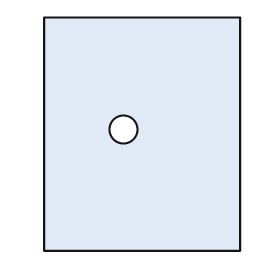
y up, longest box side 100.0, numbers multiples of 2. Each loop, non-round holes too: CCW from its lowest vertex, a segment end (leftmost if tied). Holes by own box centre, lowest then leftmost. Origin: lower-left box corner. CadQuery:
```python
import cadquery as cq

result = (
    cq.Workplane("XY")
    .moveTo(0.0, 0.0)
    .lineTo(84.0, 0.0)
    .lineTo(84.0, 100.0)
    .lineTo(0.0, 100.0)
    .close()
    .moveTo(34.0, 52.0)
    .circle(6.0)
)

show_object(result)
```